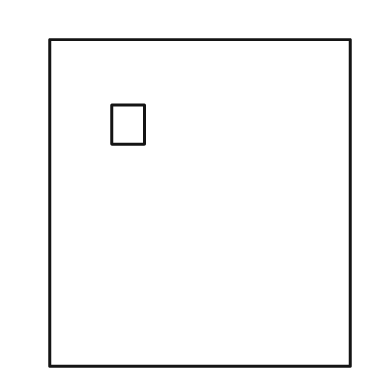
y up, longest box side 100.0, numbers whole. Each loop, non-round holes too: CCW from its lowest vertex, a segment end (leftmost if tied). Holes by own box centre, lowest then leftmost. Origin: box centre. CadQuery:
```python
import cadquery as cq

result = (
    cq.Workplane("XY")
    .moveTo(-46.0, -50.0)
    .lineTo(46.0, -50.0)
    .lineTo(46.0, 50.0)
    .lineTo(-46.0, 50.0)
    .close()
    .moveTo(-27.0, 18.0)
    .lineTo(-17.0, 18.0)
    .lineTo(-17.0, 30.0)
    .lineTo(-27.0, 30.0)
    .close()
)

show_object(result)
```